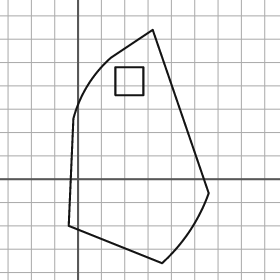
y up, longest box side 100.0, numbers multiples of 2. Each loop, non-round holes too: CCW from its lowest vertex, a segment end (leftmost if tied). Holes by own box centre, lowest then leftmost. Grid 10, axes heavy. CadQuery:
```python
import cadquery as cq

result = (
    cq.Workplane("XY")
    .moveTo(36.0, -36.0)
    .threePointArc((48.0, -22.0), (56.0, -6.0))
    .lineTo(32.0, 64.0)
    .lineTo(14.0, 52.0)
    .threePointArc((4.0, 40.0), (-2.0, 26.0))
    .lineTo(-4.0, -20.0)
    .close()
    .moveTo(16.0, 36.0)
    .lineTo(28.0, 36.0)
    .lineTo(28.0, 48.0)
    .lineTo(16.0, 48.0)
    .close()
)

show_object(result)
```